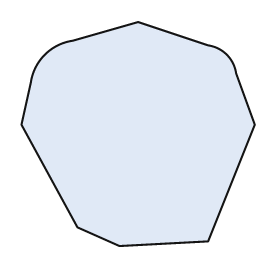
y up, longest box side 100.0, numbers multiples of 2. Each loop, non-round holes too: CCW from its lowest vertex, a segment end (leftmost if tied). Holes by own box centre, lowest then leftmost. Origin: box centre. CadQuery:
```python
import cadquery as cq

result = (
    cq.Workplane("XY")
    .moveTo(-8.0, -48.0)
    .lineTo(30.0, -46.0)
    .lineTo(50.0, 4.0)
    .lineTo(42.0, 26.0)
    .threePointArc((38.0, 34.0), (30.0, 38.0))
    .lineTo(0.0, 48.0)
    .lineTo(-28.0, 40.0)
    .threePointArc((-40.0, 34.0), (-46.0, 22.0))
    .lineTo(-50.0, 4.0)
    .lineTo(-26.0, -40.0)
    .close()
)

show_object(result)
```